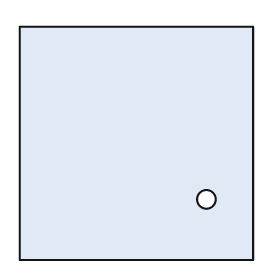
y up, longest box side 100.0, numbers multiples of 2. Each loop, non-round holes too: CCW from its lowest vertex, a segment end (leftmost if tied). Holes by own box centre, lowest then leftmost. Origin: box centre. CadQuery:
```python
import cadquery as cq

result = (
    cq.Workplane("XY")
    .moveTo(-50.0, -50.0)
    .lineTo(50.0, -50.0)
    .lineTo(50.0, 50.0)
    .lineTo(-50.0, 50.0)
    .close()
    .moveTo(30.0, -24.0)
    .circle(4.0)
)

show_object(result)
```